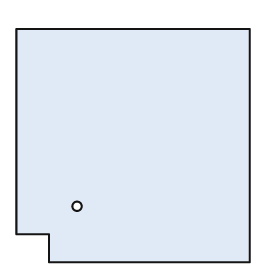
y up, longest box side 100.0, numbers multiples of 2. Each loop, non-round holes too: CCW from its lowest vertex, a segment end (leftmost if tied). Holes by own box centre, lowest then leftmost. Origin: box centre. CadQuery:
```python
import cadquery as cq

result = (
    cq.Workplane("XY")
    .moveTo(-36.0, -50.0)
    .lineTo(50.0, -50.0)
    .lineTo(50.0, 50.0)
    .lineTo(-50.0, 50.0)
    .lineTo(-50.0, -38.0)
    .lineTo(-36.0, -38.0)
    .close()
    .moveTo(-24.0, -26.0)
    .circle(2.0)
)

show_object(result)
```